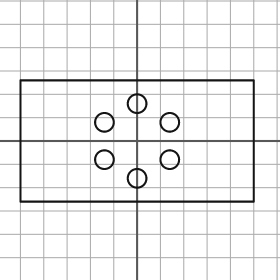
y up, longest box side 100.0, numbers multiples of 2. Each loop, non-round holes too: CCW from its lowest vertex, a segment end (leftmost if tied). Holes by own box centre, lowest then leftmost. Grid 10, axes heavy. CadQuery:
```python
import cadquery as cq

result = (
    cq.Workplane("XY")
    .moveTo(-50.0, -26.0)
    .lineTo(50.0, -26.0)
    .lineTo(50.0, 26.0)
    .lineTo(-50.0, 26.0)
    .close()
    .moveTo(0.0, -16.0)
    .circle(4.0)
    .moveTo(-14.0, -8.0)
    .circle(4.0)
    .moveTo(14.0, -8.0)
    .circle(4.0)
    .moveTo(-14.0, 8.0)
    .circle(4.0)
    .moveTo(14.0, 8.0)
    .circle(4.0)
    .moveTo(0.0, 16.0)
    .circle(4.0)
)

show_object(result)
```